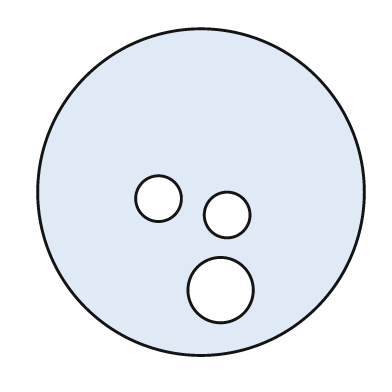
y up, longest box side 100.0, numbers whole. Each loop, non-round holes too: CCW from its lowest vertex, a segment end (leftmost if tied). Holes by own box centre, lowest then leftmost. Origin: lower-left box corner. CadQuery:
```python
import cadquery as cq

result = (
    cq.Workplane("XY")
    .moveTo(50.0, 50.0)
    .circle(50.0)
    .moveTo(56.0, 20.0)
    .circle(10.0)
    .moveTo(58.0, 43.0)
    .circle(7.0)
    .moveTo(37.0, 48.0)
    .circle(7.0)
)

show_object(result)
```